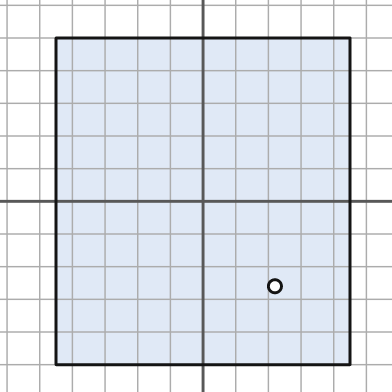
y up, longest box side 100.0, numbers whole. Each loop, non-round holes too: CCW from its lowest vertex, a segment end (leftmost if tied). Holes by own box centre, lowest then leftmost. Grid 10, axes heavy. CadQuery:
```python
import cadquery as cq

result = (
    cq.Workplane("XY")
    .moveTo(-45.0, -50.0)
    .lineTo(45.0, -50.0)
    .lineTo(45.0, 50.0)
    .lineTo(-45.0, 50.0)
    .close()
    .moveTo(22.0, -26.0)
    .circle(2.0)
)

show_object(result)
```